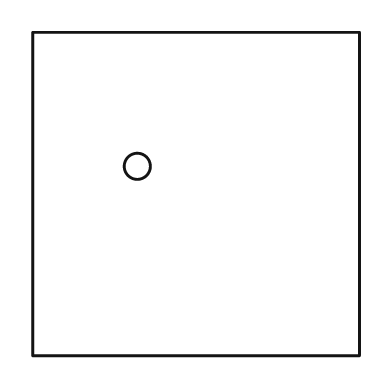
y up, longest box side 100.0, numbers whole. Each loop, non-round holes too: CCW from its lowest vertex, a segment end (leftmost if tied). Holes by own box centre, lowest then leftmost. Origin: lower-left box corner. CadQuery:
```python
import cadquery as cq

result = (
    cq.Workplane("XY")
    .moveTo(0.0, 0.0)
    .lineTo(100.0, 0.0)
    .lineTo(100.0, 99.0)
    .lineTo(0.0, 99.0)
    .close()
    .moveTo(32.0, 58.0)
    .circle(4.0)
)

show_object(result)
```